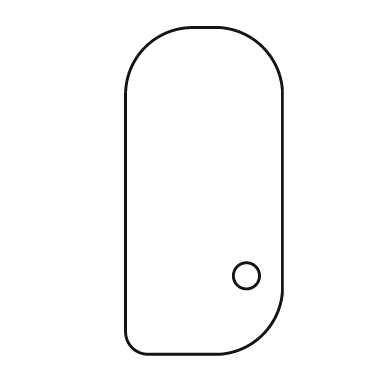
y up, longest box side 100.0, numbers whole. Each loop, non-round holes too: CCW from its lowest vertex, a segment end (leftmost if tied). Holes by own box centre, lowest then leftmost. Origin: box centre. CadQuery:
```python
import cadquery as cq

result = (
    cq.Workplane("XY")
    .moveTo(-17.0, -50.0)
    .lineTo(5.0, -50.0)
    .threePointArc((18.0, -44.0), (24.0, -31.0))
    .lineTo(24.0, 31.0)
    .threePointArc((18.0, 44.0), (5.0, 50.0))
    .lineTo(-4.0, 50.0)
    .threePointArc((-18.0, 44.0), (-24.0, 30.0))
    .lineTo(-24.0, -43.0)
    .threePointArc((-22.0, -48.0), (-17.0, -50.0))
    .close()
    .moveTo(13.0, -26.0)
    .circle(4.0)
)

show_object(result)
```